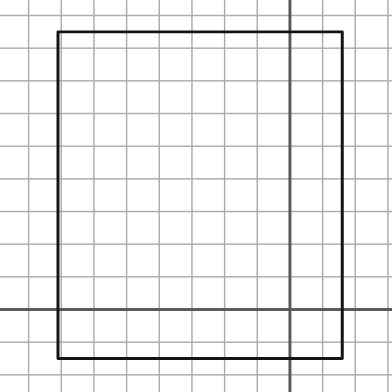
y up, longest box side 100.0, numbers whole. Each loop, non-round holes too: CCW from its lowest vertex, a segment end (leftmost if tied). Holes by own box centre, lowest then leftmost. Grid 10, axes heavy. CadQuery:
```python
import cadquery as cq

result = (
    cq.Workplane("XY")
    .moveTo(-71.0, -15.0)
    .lineTo(16.0, -15.0)
    .lineTo(16.0, 85.0)
    .lineTo(-71.0, 85.0)
    .close()
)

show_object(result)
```